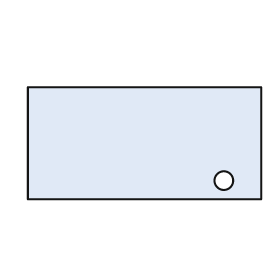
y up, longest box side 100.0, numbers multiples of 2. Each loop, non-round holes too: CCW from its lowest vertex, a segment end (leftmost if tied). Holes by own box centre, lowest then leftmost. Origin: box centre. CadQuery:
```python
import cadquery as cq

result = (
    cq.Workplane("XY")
    .moveTo(-50.0, -24.0)
    .lineTo(50.0, -24.0)
    .lineTo(50.0, 24.0)
    .lineTo(-50.0, 24.0)
    .close()
    .moveTo(34.0, -16.0)
    .circle(4.0)
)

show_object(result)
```